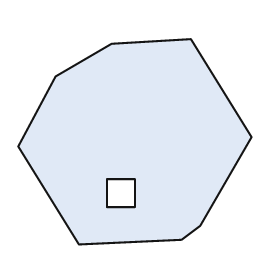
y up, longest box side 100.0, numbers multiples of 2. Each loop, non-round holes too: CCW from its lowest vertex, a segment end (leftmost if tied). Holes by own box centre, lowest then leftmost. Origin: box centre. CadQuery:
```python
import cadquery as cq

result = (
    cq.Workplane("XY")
    .moveTo(-24.0, -44.0)
    .lineTo(20.0, -42.0)
    .lineTo(28.0, -36.0)
    .lineTo(50.0, 2.0)
    .lineTo(24.0, 44.0)
    .lineTo(-10.0, 42.0)
    .lineTo(-34.0, 28.0)
    .lineTo(-50.0, -2.0)
    .close()
    .moveTo(-12.0, -28.0)
    .lineTo(0.0, -28.0)
    .lineTo(0.0, -16.0)
    .lineTo(-12.0, -16.0)
    .close()
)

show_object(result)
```